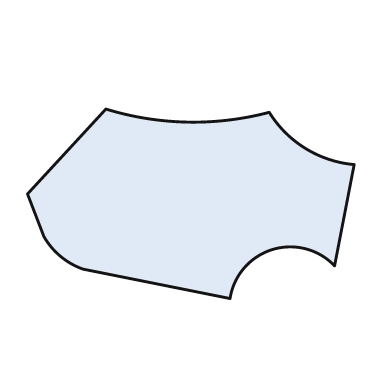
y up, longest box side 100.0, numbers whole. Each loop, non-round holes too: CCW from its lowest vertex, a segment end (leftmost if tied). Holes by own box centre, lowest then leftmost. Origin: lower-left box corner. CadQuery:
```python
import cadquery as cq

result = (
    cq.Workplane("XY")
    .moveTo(62.0, 0.0)
    .threePointArc((75.0, 15.0), (94.0, 10.0))
    .lineTo(100.0, 41.0)
    .threePointArc((85.0, 46.0), (74.0, 57.0))
    .threePointArc((49.0, 54.0), (24.0, 58.0))
    .lineTo(0.0, 32.0)
    .lineTo(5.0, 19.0)
    .threePointArc((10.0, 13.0), (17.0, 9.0))
    .close()
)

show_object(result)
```